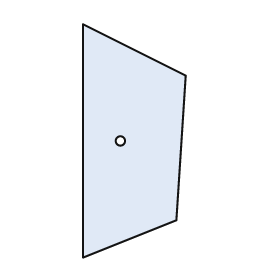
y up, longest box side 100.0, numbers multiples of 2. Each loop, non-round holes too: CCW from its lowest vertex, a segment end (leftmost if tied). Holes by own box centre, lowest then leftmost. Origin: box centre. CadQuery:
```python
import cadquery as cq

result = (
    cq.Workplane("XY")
    .moveTo(-22.0, -50.0)
    .lineTo(18.0, -34.0)
    .lineTo(22.0, 28.0)
    .lineTo(-22.0, 50.0)
    .close()
    .moveTo(-6.0, 0.0)
    .circle(2.0)
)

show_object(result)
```